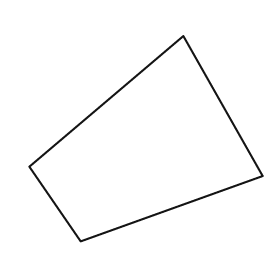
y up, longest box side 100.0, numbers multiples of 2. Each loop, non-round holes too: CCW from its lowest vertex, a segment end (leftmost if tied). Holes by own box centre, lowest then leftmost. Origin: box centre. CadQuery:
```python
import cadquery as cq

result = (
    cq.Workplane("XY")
    .moveTo(-28.0, -44.0)
    .lineTo(50.0, -16.0)
    .lineTo(16.0, 44.0)
    .lineTo(-50.0, -12.0)
    .close()
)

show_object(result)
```